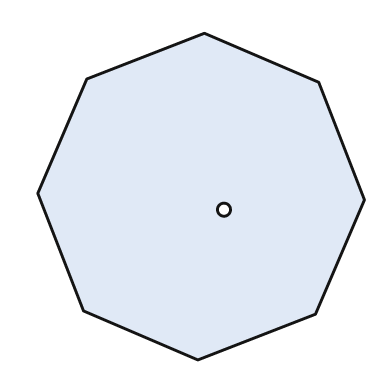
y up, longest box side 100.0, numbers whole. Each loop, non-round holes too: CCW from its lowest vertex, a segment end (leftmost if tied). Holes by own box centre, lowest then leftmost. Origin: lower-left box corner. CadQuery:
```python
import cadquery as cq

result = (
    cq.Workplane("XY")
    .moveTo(49.0, 0.0)
    .lineTo(85.0, 14.0)
    .lineTo(100.0, 49.0)
    .lineTo(86.0, 85.0)
    .lineTo(51.0, 100.0)
    .lineTo(15.0, 86.0)
    .lineTo(0.0, 51.0)
    .lineTo(14.0, 15.0)
    .close()
    .moveTo(57.0, 46.0)
    .circle(2.0)
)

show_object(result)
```